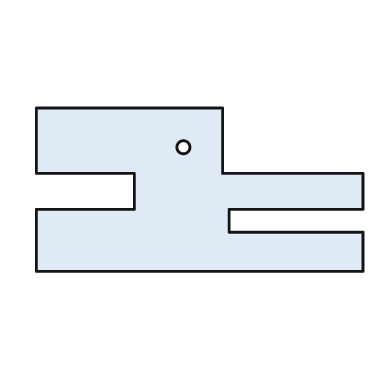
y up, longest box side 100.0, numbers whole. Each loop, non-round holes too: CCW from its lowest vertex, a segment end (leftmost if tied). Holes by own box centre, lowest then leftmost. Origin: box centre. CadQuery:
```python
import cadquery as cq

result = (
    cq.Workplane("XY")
    .moveTo(-50.0, -25.0)
    .lineTo(50.0, -25.0)
    .lineTo(50.0, -13.0)
    .lineTo(9.0, -13.0)
    .lineTo(9.0, -6.0)
    .lineTo(50.0, -6.0)
    .lineTo(50.0, 5.0)
    .lineTo(7.0, 5.0)
    .lineTo(7.0, 25.0)
    .lineTo(-50.0, 25.0)
    .lineTo(-50.0, 5.0)
    .lineTo(-20.0, 5.0)
    .lineTo(-20.0, -6.0)
    .lineTo(-50.0, -6.0)
    .close()
    .moveTo(-5.0, 13.0)
    .circle(2.0)
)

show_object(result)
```